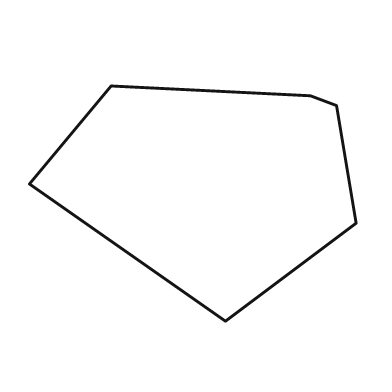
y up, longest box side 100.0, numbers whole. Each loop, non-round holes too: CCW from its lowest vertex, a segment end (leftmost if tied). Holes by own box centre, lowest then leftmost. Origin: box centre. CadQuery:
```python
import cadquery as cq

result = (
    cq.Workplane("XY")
    .moveTo(10.0, -36.0)
    .lineTo(50.0, -6.0)
    .lineTo(44.0, 30.0)
    .lineTo(36.0, 33.0)
    .lineTo(-25.0, 36.0)
    .lineTo(-50.0, 6.0)
    .close()
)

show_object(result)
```